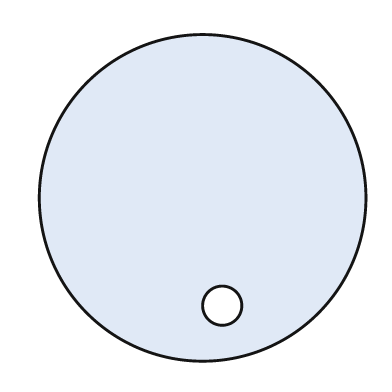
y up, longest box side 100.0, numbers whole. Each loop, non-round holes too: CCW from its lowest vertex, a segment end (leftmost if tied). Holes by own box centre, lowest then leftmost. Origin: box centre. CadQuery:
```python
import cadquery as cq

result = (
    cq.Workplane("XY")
    .moveTo(0.0, 0.0)
    .circle(50.0)
    .moveTo(6.0, -33.0)
    .circle(6.0)
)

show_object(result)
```